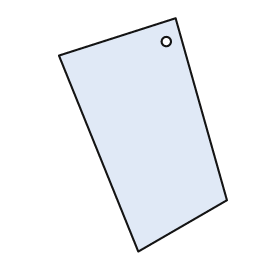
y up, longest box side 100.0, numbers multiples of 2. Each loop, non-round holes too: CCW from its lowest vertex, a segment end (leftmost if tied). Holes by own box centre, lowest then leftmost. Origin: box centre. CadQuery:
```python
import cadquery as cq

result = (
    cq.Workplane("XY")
    .moveTo(-2.0, -50.0)
    .lineTo(36.0, -28.0)
    .lineTo(14.0, 50.0)
    .lineTo(-36.0, 34.0)
    .close()
    .moveTo(10.0, 40.0)
    .circle(2.0)
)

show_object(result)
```